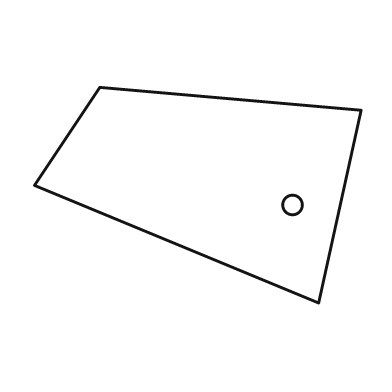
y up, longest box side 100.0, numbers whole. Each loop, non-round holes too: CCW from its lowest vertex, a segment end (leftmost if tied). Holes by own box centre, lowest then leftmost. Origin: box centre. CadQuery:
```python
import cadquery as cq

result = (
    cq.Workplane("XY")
    .moveTo(37.0, -33.0)
    .lineTo(50.0, 26.0)
    .lineTo(-30.0, 33.0)
    .lineTo(-50.0, 3.0)
    .close()
    .moveTo(29.0, -3.0)
    .circle(3.0)
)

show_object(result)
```